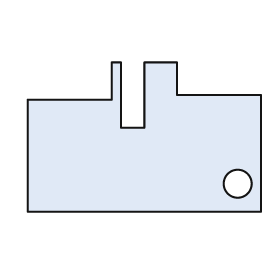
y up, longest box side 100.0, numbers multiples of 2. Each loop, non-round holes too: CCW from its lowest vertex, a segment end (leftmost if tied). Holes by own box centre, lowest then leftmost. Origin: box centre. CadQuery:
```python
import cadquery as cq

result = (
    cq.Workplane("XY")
    .moveTo(-50.0, -32.0)
    .lineTo(50.0, -32.0)
    .lineTo(50.0, 18.0)
    .lineTo(14.0, 18.0)
    .lineTo(14.0, 32.0)
    .lineTo(0.0, 32.0)
    .lineTo(0.0, 4.0)
    .lineTo(-10.0, 4.0)
    .lineTo(-10.0, 32.0)
    .lineTo(-14.0, 32.0)
    .lineTo(-14.0, 16.0)
    .lineTo(-50.0, 16.0)
    .close()
    .moveTo(40.0, -20.0)
    .circle(6.0)
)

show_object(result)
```